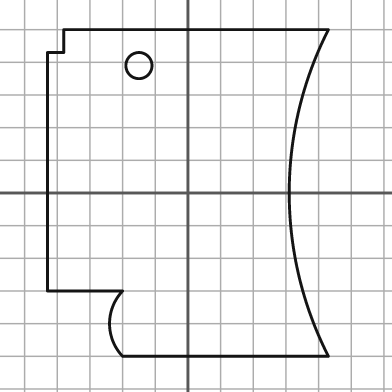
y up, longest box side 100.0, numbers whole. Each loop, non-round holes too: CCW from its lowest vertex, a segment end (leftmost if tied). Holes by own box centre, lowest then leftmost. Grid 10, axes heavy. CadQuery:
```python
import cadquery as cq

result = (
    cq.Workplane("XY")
    .moveTo(-20.0, -50.0)
    .lineTo(43.0, -50.0)
    .threePointArc((31.0, 0.0), (43.0, 50.0))
    .lineTo(-38.0, 50.0)
    .lineTo(-38.0, 43.0)
    .lineTo(-43.0, 43.0)
    .lineTo(-43.0, -30.0)
    .lineTo(-20.0, -30.0)
    .threePointArc((-24.0, -40.0), (-20.0, -50.0))
    .close()
    .moveTo(-15.0, 39.0)
    .circle(4.0)
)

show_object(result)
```